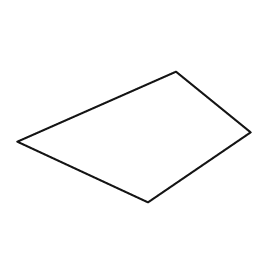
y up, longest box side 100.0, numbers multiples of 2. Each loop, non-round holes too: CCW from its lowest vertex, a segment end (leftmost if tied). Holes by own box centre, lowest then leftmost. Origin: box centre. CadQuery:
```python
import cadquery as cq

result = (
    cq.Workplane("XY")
    .moveTo(6.0, -28.0)
    .lineTo(50.0, 2.0)
    .lineTo(18.0, 28.0)
    .lineTo(-50.0, -2.0)
    .close()
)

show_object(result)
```